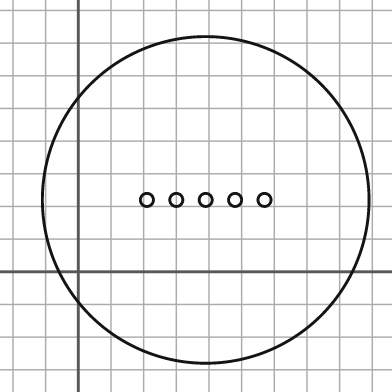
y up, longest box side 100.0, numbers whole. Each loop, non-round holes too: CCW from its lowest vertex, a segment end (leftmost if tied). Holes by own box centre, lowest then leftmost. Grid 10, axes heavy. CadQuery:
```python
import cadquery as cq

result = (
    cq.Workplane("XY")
    .moveTo(39.0, 22.0)
    .circle(50.0)
    .moveTo(21.0, 22.0)
    .circle(2.0)
    .moveTo(30.0, 22.0)
    .circle(2.0)
    .moveTo(39.0, 22.0)
    .circle(2.0)
    .moveTo(48.0, 22.0)
    .circle(2.0)
    .moveTo(57.0, 22.0)
    .circle(2.0)
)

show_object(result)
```